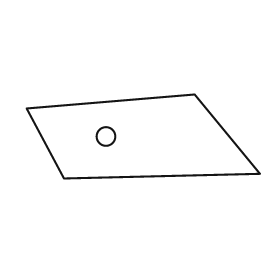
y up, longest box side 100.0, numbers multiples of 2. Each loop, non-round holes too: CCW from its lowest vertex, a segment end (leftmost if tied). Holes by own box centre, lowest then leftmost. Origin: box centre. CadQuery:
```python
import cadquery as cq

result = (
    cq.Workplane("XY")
    .moveTo(-34.0, -18.0)
    .lineTo(50.0, -16.0)
    .lineTo(22.0, 18.0)
    .lineTo(-50.0, 12.0)
    .close()
    .moveTo(-16.0, 0.0)
    .circle(4.0)
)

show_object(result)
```